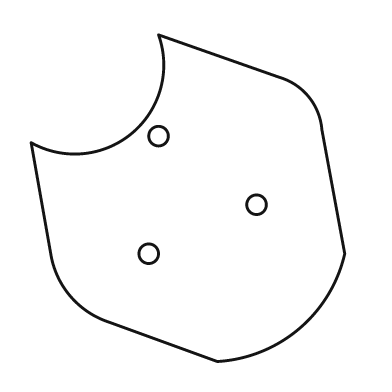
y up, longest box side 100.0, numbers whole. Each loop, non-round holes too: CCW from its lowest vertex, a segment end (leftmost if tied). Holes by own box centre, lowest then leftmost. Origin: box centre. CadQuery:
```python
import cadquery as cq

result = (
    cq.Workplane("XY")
    .moveTo(9.0, -50.0)
    .threePointArc((34.0, -40.0), (48.0, -17.0))
    .lineTo(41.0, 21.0)
    .threePointArc((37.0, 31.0), (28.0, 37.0))
    .lineTo(-9.0, 50.0)
    .threePointArc((-17.0, 20.0), (-48.0, 17.0))
    .lineTo(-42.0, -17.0)
    .threePointArc((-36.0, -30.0), (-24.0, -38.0))
    .close()
    .moveTo(-12.0, -17.0)
    .circle(3.0)
    .moveTo(21.0, -2.0)
    .circle(3.0)
    .moveTo(-9.0, 19.0)
    .circle(3.0)
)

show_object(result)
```